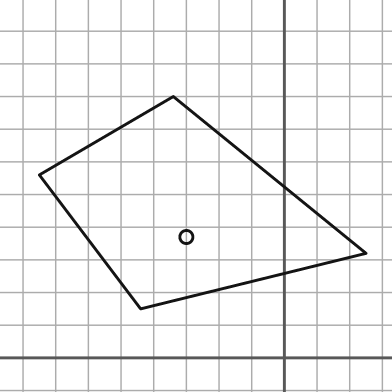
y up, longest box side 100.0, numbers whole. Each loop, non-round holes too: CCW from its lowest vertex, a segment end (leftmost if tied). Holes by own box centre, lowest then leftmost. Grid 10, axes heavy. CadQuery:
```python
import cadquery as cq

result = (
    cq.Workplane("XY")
    .moveTo(-44.0, 15.0)
    .lineTo(25.0, 32.0)
    .lineTo(-34.0, 80.0)
    .lineTo(-75.0, 56.0)
    .close()
    .moveTo(-30.0, 37.0)
    .circle(2.0)
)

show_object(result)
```